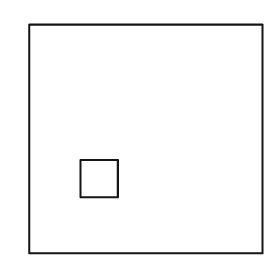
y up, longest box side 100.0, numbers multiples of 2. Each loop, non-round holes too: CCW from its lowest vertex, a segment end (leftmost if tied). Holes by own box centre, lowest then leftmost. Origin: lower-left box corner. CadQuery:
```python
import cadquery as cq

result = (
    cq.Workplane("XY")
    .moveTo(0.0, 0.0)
    .lineTo(100.0, 0.0)
    .lineTo(100.0, 98.0)
    .lineTo(0.0, 98.0)
    .close()
    .moveTo(22.0, 24.0)
    .lineTo(38.0, 24.0)
    .lineTo(38.0, 40.0)
    .lineTo(22.0, 40.0)
    .close()
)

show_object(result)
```